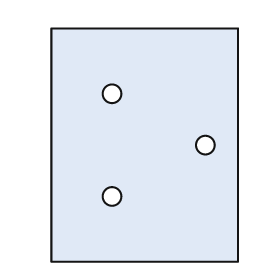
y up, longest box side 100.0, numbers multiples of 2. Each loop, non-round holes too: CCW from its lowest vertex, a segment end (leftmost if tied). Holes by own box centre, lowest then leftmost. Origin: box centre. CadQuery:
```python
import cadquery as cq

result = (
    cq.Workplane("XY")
    .moveTo(-40.0, -50.0)
    .lineTo(40.0, -50.0)
    .lineTo(40.0, 50.0)
    .lineTo(-40.0, 50.0)
    .close()
    .moveTo(-14.0, -22.0)
    .circle(4.0)
    .moveTo(26.0, 0.0)
    .circle(4.0)
    .moveTo(-14.0, 22.0)
    .circle(4.0)
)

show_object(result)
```